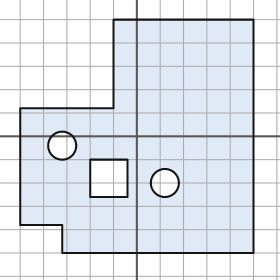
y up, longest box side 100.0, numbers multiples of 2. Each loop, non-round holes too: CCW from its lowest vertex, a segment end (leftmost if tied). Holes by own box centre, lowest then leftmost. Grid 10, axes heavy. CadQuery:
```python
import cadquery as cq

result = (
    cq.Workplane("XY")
    .moveTo(-32.0, -50.0)
    .lineTo(50.0, -50.0)
    .lineTo(50.0, 50.0)
    .lineTo(-10.0, 50.0)
    .lineTo(-10.0, 12.0)
    .lineTo(-50.0, 12.0)
    .lineTo(-50.0, -38.0)
    .lineTo(-32.0, -38.0)
    .close()
    .moveTo(12.0, -20.0)
    .circle(6.0)
    .moveTo(-20.0, -26.0)
    .lineTo(-4.0, -26.0)
    .lineTo(-4.0, -10.0)
    .lineTo(-20.0, -10.0)
    .close()
    .moveTo(-32.0, -4.0)
    .circle(6.0)
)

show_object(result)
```